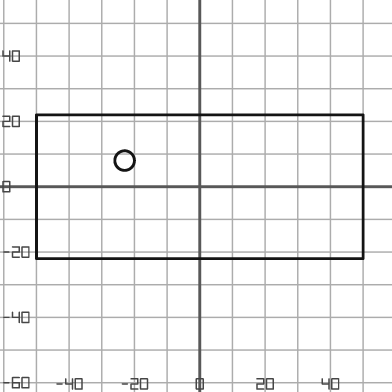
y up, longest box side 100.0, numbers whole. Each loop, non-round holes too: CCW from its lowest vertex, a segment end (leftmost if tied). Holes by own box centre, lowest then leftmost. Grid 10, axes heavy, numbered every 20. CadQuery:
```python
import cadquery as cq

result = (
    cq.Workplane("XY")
    .moveTo(-50.0, -22.0)
    .lineTo(50.0, -22.0)
    .lineTo(50.0, 22.0)
    .lineTo(-50.0, 22.0)
    .close()
    .moveTo(-23.0, 8.0)
    .circle(3.0)
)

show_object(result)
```